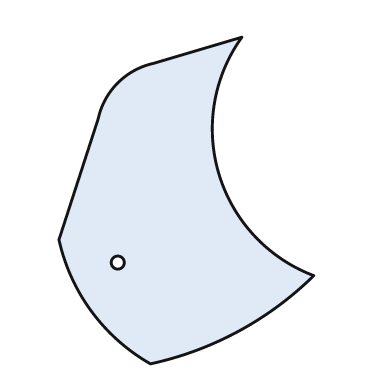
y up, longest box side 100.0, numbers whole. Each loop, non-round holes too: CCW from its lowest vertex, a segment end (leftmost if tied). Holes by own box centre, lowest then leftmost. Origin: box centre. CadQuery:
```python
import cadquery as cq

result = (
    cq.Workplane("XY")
    .moveTo(-11.0, -50.0)
    .threePointArc((16.0, -40.0), (39.0, -23.0))
    .threePointArc((10.0, 8.0), (17.0, 50.0))
    .lineTo(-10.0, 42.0)
    .threePointArc((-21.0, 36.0), (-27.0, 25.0))
    .lineTo(-39.0, -12.0)
    .threePointArc((-29.0, -34.0), (-11.0, -50.0))
    .close()
    .moveTo(-21.0, -19.0)
    .circle(2.0)
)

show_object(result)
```